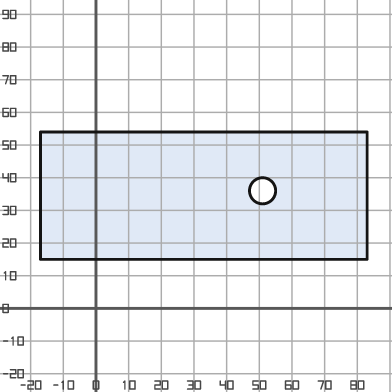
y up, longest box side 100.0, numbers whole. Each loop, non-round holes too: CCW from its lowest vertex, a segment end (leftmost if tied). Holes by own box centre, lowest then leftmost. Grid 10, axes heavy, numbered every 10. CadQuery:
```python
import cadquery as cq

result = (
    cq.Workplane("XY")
    .moveTo(-17.0, 15.0)
    .lineTo(83.0, 15.0)
    .lineTo(83.0, 54.0)
    .lineTo(-17.0, 54.0)
    .close()
    .moveTo(51.0, 36.0)
    .circle(4.0)
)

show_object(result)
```